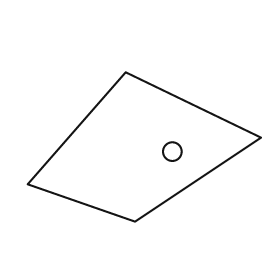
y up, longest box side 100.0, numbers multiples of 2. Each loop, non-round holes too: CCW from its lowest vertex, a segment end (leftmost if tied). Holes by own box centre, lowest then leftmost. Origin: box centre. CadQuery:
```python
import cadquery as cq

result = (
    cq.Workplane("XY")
    .moveTo(-4.0, -32.0)
    .lineTo(50.0, 4.0)
    .lineTo(-8.0, 32.0)
    .lineTo(-50.0, -16.0)
    .close()
    .moveTo(12.0, -2.0)
    .circle(4.0)
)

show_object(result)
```